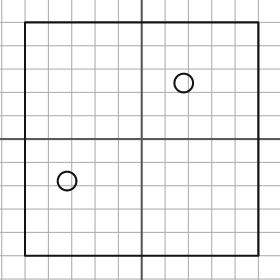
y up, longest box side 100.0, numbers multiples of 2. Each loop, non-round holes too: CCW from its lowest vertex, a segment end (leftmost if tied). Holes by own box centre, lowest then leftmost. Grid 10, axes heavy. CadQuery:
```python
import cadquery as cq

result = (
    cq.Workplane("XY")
    .moveTo(-50.0, -50.0)
    .lineTo(50.0, -50.0)
    .lineTo(50.0, 50.0)
    .lineTo(-50.0, 50.0)
    .close()
    .moveTo(-32.0, -18.0)
    .circle(4.0)
    .moveTo(18.0, 24.0)
    .circle(4.0)
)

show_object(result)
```